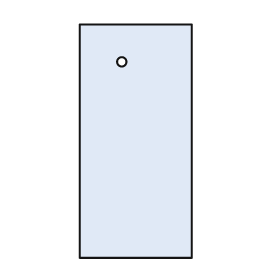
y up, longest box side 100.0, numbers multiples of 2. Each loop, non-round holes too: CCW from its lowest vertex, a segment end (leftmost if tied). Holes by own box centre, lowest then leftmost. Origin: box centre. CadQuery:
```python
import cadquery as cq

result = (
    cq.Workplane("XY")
    .moveTo(-24.0, -50.0)
    .lineTo(24.0, -50.0)
    .lineTo(24.0, 50.0)
    .lineTo(-24.0, 50.0)
    .close()
    .moveTo(-6.0, 34.0)
    .circle(2.0)
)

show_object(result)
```